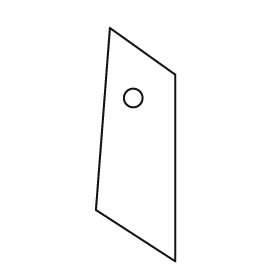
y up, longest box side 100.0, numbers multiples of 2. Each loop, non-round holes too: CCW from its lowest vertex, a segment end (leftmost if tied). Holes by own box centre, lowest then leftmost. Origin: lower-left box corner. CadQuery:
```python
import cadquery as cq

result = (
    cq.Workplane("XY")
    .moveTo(34.0, 0.0)
    .lineTo(34.0, 80.0)
    .lineTo(6.0, 100.0)
    .lineTo(0.0, 22.0)
    .close()
    .moveTo(16.0, 70.0)
    .circle(4.0)
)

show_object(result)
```